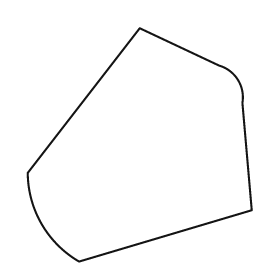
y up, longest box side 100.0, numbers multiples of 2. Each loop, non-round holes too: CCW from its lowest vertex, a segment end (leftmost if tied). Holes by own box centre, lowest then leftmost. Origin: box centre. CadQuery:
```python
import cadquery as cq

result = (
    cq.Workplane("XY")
    .moveTo(-26.0, -50.0)
    .lineTo(48.0, -28.0)
    .lineTo(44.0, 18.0)
    .threePointArc((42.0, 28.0), (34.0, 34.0))
    .lineTo(0.0, 50.0)
    .lineTo(-48.0, -12.0)
    .threePointArc((-42.0, -34.0), (-26.0, -50.0))
    .close()
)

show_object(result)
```